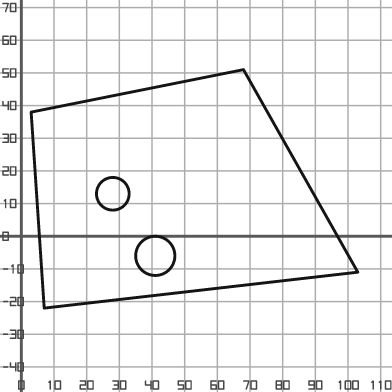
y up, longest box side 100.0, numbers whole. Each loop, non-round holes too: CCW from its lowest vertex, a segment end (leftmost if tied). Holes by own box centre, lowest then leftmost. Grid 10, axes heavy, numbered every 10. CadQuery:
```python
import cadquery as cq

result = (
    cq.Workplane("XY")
    .moveTo(7.0, -22.0)
    .lineTo(103.0, -11.0)
    .lineTo(68.0, 51.0)
    .lineTo(3.0, 38.0)
    .close()
    .moveTo(41.0, -6.0)
    .circle(6.0)
    .moveTo(28.0, 13.0)
    .circle(5.0)
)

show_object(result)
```